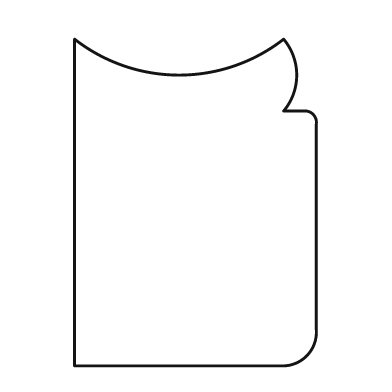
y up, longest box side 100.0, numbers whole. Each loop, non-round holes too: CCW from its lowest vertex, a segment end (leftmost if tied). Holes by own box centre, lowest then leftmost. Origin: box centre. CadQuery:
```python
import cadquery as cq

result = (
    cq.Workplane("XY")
    .moveTo(-37.0, -50.0)
    .lineTo(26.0, -50.0)
    .threePointArc((34.0, -47.0), (37.0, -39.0))
    .lineTo(37.0, 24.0)
    .threePointArc((36.0, 27.0), (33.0, 28.0))
    .lineTo(27.0, 28.0)
    .threePointArc((31.0, 39.0), (27.0, 50.0))
    .threePointArc((-5.0, 39.0), (-37.0, 50.0))
    .close()
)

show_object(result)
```